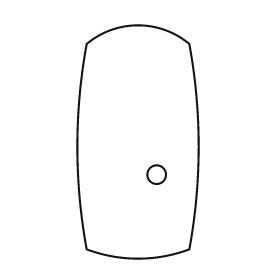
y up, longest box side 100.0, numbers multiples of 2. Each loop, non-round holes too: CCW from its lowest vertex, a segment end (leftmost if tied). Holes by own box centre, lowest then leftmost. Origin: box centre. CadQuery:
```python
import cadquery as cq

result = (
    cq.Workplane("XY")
    .moveTo(-22.0, -46.0)
    .threePointArc((0.0, -50.0), (22.0, -46.0))
    .threePointArc((26.0, -2.0), (22.0, 42.0))
    .threePointArc((0.0, 50.0), (-22.0, 42.0))
    .threePointArc((-26.0, -2.0), (-22.0, -46.0))
    .close()
    .moveTo(8.0, -14.0)
    .circle(4.0)
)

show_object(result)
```